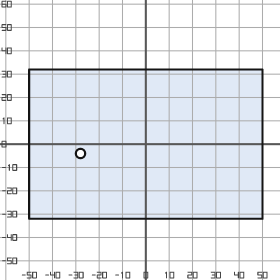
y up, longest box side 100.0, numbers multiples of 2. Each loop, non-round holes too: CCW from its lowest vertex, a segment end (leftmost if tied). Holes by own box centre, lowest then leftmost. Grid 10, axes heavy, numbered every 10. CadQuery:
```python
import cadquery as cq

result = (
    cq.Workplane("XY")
    .moveTo(-50.0, -32.0)
    .lineTo(50.0, -32.0)
    .lineTo(50.0, 32.0)
    .lineTo(-50.0, 32.0)
    .close()
    .moveTo(-28.0, -4.0)
    .circle(2.0)
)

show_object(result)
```